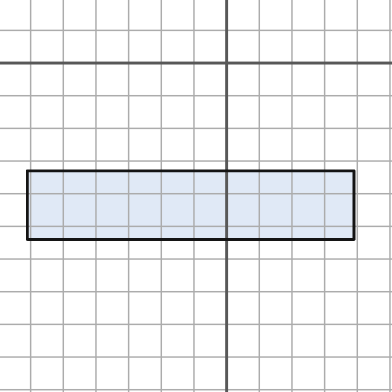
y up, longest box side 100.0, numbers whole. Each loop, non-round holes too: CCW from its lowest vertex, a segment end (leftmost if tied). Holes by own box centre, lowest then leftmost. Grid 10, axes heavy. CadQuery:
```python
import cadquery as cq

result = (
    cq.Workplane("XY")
    .moveTo(-61.0, -54.0)
    .lineTo(39.0, -54.0)
    .lineTo(39.0, -33.0)
    .lineTo(-61.0, -33.0)
    .close()
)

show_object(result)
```